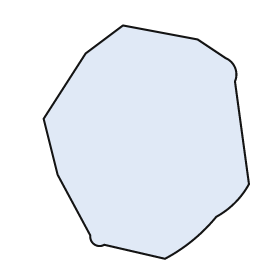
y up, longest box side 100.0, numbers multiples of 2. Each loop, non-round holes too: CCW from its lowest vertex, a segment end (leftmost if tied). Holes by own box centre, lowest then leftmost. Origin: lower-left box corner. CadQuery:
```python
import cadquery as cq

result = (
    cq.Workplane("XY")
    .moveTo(52.0, 0.0)
    .threePointArc((64.0, 8.0), (74.0, 18.0))
    .threePointArc((82.0, 24.0), (88.0, 32.0))
    .lineTo(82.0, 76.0)
    .threePointArc((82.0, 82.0), (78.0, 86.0))
    .lineTo(66.0, 94.0)
    .lineTo(34.0, 100.0)
    .lineTo(18.0, 88.0)
    .lineTo(0.0, 60.0)
    .lineTo(6.0, 36.0)
    .lineTo(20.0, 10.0)
    .threePointArc((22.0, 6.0), (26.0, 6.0))
    .close()
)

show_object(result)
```